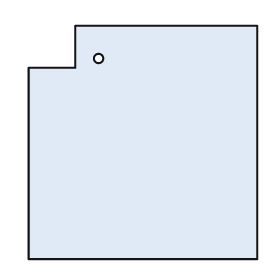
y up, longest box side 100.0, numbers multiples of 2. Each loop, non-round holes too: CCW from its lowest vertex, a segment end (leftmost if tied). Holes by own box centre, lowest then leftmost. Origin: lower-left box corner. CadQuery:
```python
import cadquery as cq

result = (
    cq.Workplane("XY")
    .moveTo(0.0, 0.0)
    .lineTo(98.0, 0.0)
    .lineTo(98.0, 100.0)
    .lineTo(20.0, 100.0)
    .lineTo(20.0, 82.0)
    .lineTo(0.0, 82.0)
    .close()
    .moveTo(30.0, 86.0)
    .circle(2.0)
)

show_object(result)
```